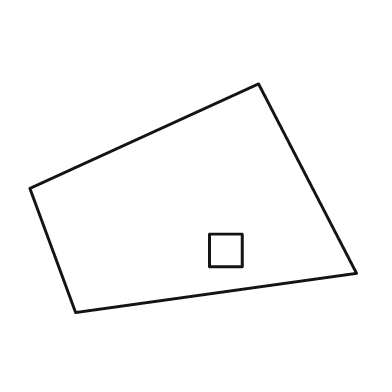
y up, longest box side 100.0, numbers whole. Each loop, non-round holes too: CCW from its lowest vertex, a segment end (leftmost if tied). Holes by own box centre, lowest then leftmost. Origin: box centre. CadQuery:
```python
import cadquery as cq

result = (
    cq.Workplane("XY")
    .moveTo(-36.0, -35.0)
    .lineTo(50.0, -23.0)
    .lineTo(20.0, 35.0)
    .lineTo(-50.0, 3.0)
    .close()
    .moveTo(5.0, -21.0)
    .lineTo(15.0, -21.0)
    .lineTo(15.0, -11.0)
    .lineTo(5.0, -11.0)
    .close()
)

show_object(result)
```